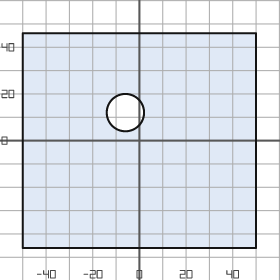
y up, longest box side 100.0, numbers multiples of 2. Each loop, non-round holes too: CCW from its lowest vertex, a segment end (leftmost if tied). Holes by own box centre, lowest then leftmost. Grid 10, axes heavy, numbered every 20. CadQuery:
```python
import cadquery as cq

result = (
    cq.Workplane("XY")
    .moveTo(-50.0, -46.0)
    .lineTo(50.0, -46.0)
    .lineTo(50.0, 46.0)
    .lineTo(-50.0, 46.0)
    .close()
    .moveTo(-6.0, 12.0)
    .circle(8.0)
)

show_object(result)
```